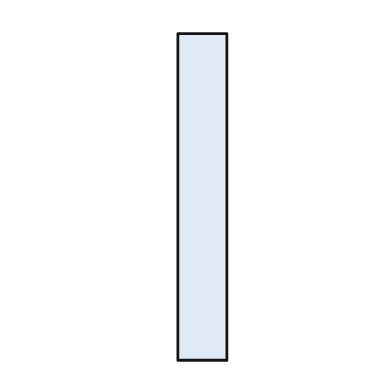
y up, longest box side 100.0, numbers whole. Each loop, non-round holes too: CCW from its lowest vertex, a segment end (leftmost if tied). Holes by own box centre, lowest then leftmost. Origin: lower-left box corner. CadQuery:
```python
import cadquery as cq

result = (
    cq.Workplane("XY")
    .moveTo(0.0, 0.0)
    .lineTo(15.0, 0.0)
    .lineTo(15.0, 100.0)
    .lineTo(0.0, 100.0)
    .close()
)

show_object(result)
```